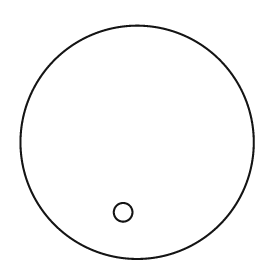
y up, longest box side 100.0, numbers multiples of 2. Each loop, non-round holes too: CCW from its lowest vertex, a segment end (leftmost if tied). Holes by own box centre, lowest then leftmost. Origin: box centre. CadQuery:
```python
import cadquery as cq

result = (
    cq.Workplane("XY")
    .moveTo(0.0, 0.0)
    .circle(50.0)
    .moveTo(-6.0, -30.0)
    .circle(4.0)
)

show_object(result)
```